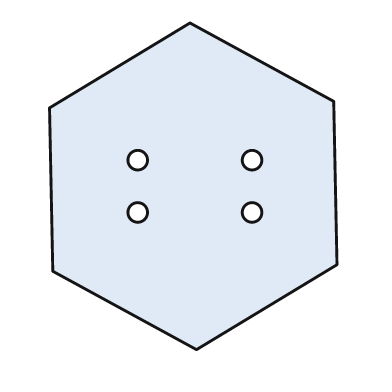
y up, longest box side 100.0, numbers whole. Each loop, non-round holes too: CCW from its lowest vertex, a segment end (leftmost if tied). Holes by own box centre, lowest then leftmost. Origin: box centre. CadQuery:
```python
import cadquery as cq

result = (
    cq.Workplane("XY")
    .moveTo(1.0, -50.0)
    .lineTo(44.0, -24.0)
    .lineTo(43.0, 26.0)
    .lineTo(-1.0, 50.0)
    .lineTo(-44.0, 24.0)
    .lineTo(-43.0, -26.0)
    .close()
    .moveTo(-17.0, -8.0)
    .circle(3.0)
    .moveTo(18.0, -8.0)
    .circle(3.0)
    .moveTo(-17.0, 8.0)
    .circle(3.0)
    .moveTo(18.0, 8.0)
    .circle(3.0)
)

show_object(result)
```